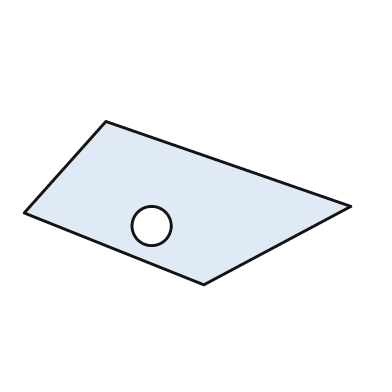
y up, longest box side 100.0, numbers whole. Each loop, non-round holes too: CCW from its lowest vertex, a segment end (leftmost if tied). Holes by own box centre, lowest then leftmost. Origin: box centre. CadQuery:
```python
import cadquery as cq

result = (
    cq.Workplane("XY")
    .moveTo(5.0, -25.0)
    .lineTo(50.0, -1.0)
    .lineTo(-25.0, 25.0)
    .lineTo(-50.0, -3.0)
    .close()
    .moveTo(-11.0, -7.0)
    .circle(6.0)
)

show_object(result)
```